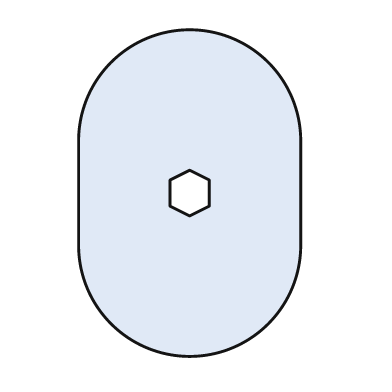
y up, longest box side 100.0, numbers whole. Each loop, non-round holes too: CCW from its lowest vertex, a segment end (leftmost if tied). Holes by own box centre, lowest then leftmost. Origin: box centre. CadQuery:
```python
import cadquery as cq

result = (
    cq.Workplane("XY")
    .moveTo(-34.0, -16.0)
    .threePointArc((0.0, -50.0), (34.0, -16.0))
    .lineTo(34.0, 16.0)
    .threePointArc((0.0, 50.0), (-34.0, 16.0))
    .close()
    .moveTo(0.0, -7.0)
    .lineTo(6.0, -4.0)
    .lineTo(6.0, 4.0)
    .lineTo(0.0, 7.0)
    .lineTo(-6.0, 4.0)
    .lineTo(-6.0, -4.0)
    .close()
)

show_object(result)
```